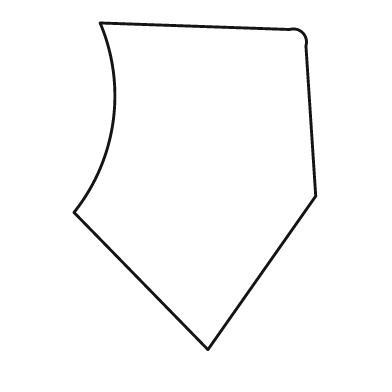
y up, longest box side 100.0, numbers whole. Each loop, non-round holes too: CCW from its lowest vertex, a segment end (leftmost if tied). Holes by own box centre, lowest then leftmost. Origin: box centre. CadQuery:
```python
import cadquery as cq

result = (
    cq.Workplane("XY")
    .moveTo(4.0, -50.0)
    .lineTo(37.0, -3.0)
    .lineTo(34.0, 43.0)
    .threePointArc((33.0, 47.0), (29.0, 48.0))
    .lineTo(-29.0, 50.0)
    .threePointArc((-25.0, 20.0), (-37.0, -8.0))
    .close()
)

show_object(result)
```